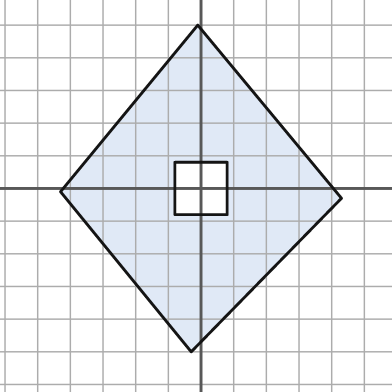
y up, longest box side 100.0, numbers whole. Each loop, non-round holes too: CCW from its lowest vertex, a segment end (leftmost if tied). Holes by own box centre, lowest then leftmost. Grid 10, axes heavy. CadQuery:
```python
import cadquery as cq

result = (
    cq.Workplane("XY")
    .moveTo(-3.0, -50.0)
    .lineTo(43.0, -3.0)
    .lineTo(-1.0, 50.0)
    .lineTo(-43.0, -1.0)
    .close()
    .moveTo(-8.0, -8.0)
    .lineTo(8.0, -8.0)
    .lineTo(8.0, 8.0)
    .lineTo(-8.0, 8.0)
    .close()
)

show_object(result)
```